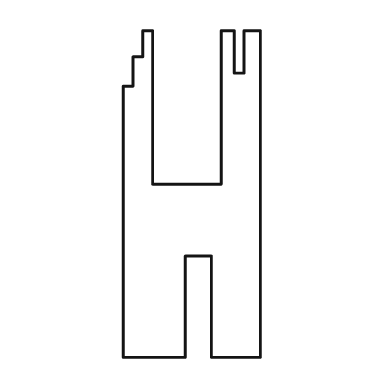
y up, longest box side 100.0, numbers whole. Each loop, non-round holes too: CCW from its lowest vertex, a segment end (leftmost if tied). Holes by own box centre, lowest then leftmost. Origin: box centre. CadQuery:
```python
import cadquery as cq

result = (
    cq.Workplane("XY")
    .moveTo(-21.0, -50.0)
    .lineTo(-2.0, -50.0)
    .lineTo(-2.0, -19.0)
    .lineTo(6.0, -19.0)
    .lineTo(6.0, -50.0)
    .lineTo(21.0, -50.0)
    .lineTo(21.0, 50.0)
    .lineTo(16.0, 50.0)
    .lineTo(16.0, 37.0)
    .lineTo(13.0, 37.0)
    .lineTo(13.0, 50.0)
    .lineTo(9.0, 50.0)
    .lineTo(9.0, 3.0)
    .lineTo(-12.0, 3.0)
    .lineTo(-12.0, 50.0)
    .lineTo(-15.0, 50.0)
    .lineTo(-15.0, 42.0)
    .lineTo(-18.0, 42.0)
    .lineTo(-18.0, 33.0)
    .lineTo(-21.0, 33.0)
    .close()
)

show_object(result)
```